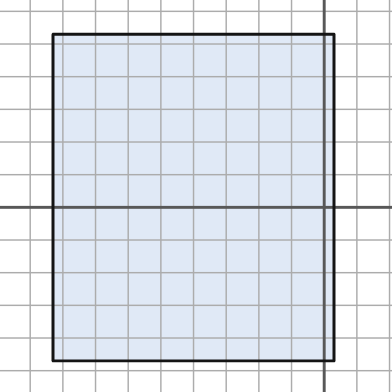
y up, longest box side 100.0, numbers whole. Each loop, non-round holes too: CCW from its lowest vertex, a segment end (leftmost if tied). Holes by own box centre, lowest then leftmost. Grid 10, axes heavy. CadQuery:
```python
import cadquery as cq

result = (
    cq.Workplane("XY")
    .moveTo(-83.0, -47.0)
    .lineTo(3.0, -47.0)
    .lineTo(3.0, 53.0)
    .lineTo(-83.0, 53.0)
    .close()
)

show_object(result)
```